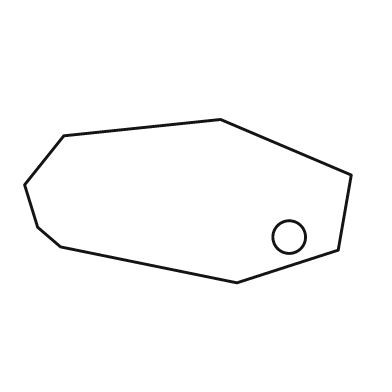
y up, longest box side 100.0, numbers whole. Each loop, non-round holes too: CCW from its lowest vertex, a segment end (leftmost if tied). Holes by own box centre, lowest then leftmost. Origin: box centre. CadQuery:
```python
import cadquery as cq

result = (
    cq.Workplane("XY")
    .moveTo(15.0, -25.0)
    .lineTo(46.0, -15.0)
    .lineTo(50.0, 8.0)
    .lineTo(10.0, 25.0)
    .lineTo(-38.0, 20.0)
    .lineTo(-50.0, 5.0)
    .lineTo(-46.0, -8.0)
    .lineTo(-39.0, -14.0)
    .close()
    .moveTo(31.0, -11.0)
    .circle(5.0)
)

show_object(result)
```